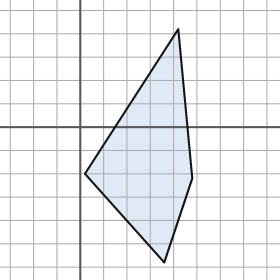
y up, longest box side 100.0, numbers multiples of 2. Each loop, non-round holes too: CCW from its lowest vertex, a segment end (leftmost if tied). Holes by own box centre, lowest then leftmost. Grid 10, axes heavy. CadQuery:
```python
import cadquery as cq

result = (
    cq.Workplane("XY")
    .moveTo(36.0, -58.0)
    .lineTo(48.0, -22.0)
    .lineTo(42.0, 42.0)
    .lineTo(2.0, -20.0)
    .close()
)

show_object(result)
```